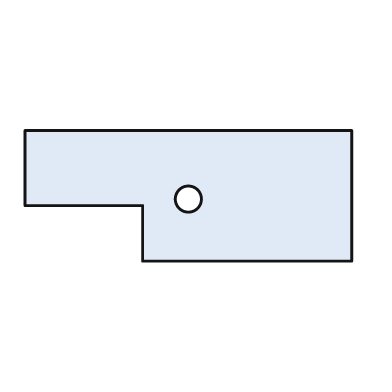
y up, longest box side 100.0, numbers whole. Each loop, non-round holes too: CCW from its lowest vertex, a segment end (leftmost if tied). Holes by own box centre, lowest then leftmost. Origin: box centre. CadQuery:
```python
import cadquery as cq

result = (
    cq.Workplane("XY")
    .moveTo(-14.0, -20.0)
    .lineTo(50.0, -20.0)
    .lineTo(50.0, 20.0)
    .lineTo(-50.0, 20.0)
    .lineTo(-50.0, -3.0)
    .lineTo(-14.0, -3.0)
    .close()
    .moveTo(0.0, -1.0)
    .circle(4.0)
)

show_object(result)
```